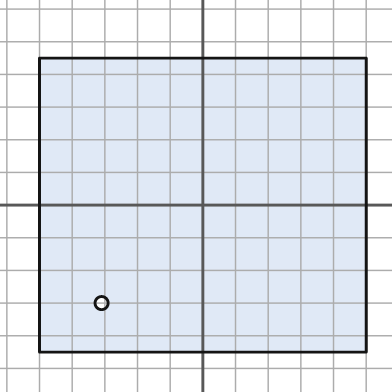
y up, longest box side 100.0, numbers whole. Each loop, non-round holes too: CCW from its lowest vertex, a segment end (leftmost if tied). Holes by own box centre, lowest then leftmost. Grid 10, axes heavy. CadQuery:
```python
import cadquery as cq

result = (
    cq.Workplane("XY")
    .moveTo(-50.0, -45.0)
    .lineTo(50.0, -45.0)
    .lineTo(50.0, 45.0)
    .lineTo(-50.0, 45.0)
    .close()
    .moveTo(-31.0, -30.0)
    .circle(2.0)
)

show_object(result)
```